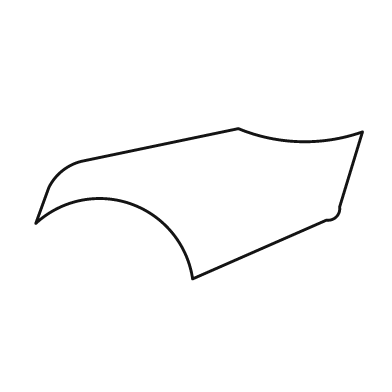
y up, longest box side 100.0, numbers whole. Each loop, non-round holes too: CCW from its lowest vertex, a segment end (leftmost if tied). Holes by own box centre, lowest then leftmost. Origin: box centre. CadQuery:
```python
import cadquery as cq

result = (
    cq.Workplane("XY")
    .moveTo(-2.0, -23.0)
    .lineTo(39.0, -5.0)
    .threePointArc((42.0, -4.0), (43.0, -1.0))
    .lineTo(50.0, 22.0)
    .threePointArc((31.0, 19.0), (12.0, 23.0))
    .lineTo(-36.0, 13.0)
    .threePointArc((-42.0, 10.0), (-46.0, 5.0))
    .lineTo(-50.0, -6.0)
    .threePointArc((-21.0, 0.0), (-2.0, -23.0))
    .close()
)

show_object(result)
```